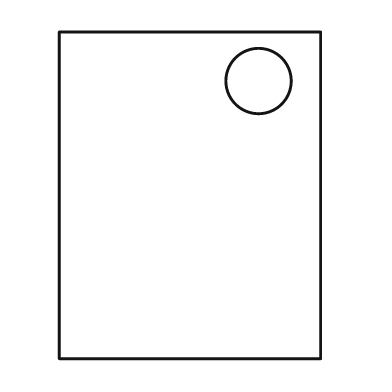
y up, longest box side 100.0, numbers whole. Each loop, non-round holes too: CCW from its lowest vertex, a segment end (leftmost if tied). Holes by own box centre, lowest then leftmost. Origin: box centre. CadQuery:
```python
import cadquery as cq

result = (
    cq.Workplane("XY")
    .moveTo(-40.0, -50.0)
    .lineTo(40.0, -50.0)
    .lineTo(40.0, 50.0)
    .lineTo(-40.0, 50.0)
    .close()
    .moveTo(21.0, 35.0)
    .circle(10.0)
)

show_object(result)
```